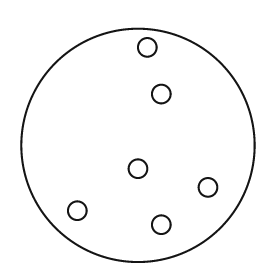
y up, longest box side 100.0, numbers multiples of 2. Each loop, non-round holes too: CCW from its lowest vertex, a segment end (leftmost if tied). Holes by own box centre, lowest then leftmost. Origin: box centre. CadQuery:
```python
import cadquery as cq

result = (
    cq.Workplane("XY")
    .moveTo(0.0, 0.0)
    .circle(50.0)
    .moveTo(10.0, -34.0)
    .circle(4.0)
    .moveTo(-26.0, -28.0)
    .circle(4.0)
    .moveTo(30.0, -18.0)
    .circle(4.0)
    .moveTo(0.0, -10.0)
    .circle(4.0)
    .moveTo(10.0, 22.0)
    .circle(4.0)
    .moveTo(4.0, 42.0)
    .circle(4.0)
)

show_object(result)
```